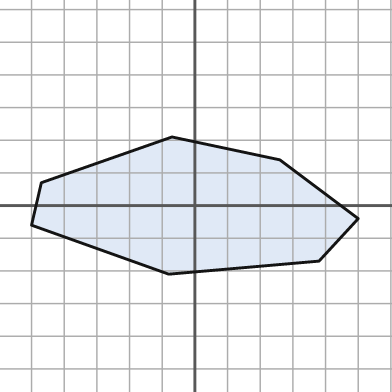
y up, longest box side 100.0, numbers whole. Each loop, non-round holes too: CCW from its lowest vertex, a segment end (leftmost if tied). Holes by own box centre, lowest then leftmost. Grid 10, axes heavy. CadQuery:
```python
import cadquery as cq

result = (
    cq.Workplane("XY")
    .moveTo(-8.0, -21.0)
    .lineTo(38.0, -17.0)
    .lineTo(50.0, -4.0)
    .lineTo(26.0, 14.0)
    .lineTo(-7.0, 21.0)
    .lineTo(-47.0, 7.0)
    .lineTo(-50.0, -6.0)
    .close()
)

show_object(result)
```